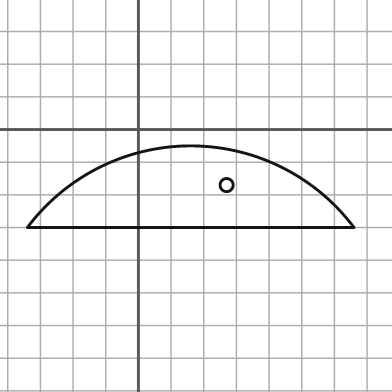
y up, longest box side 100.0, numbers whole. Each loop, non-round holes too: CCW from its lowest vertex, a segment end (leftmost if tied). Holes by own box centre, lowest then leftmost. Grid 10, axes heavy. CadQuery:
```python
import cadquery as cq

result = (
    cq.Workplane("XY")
    .moveTo(-34.0, -30.0)
    .lineTo(66.0, -30.0)
    .threePointArc((16.0, -5.0), (-34.0, -30.0))
    .close()
    .moveTo(27.0, -17.0)
    .circle(2.0)
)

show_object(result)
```